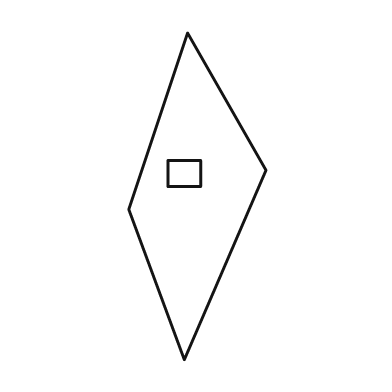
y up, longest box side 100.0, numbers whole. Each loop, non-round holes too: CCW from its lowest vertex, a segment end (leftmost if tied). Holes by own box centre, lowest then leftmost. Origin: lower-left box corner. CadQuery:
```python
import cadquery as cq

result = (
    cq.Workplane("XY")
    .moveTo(17.0, 0.0)
    .lineTo(42.0, 58.0)
    .lineTo(18.0, 100.0)
    .lineTo(0.0, 46.0)
    .close()
    .moveTo(12.0, 53.0)
    .lineTo(22.0, 53.0)
    .lineTo(22.0, 61.0)
    .lineTo(12.0, 61.0)
    .close()
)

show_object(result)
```